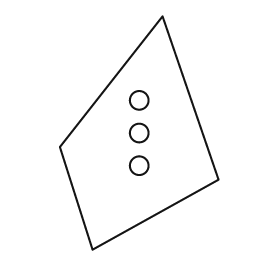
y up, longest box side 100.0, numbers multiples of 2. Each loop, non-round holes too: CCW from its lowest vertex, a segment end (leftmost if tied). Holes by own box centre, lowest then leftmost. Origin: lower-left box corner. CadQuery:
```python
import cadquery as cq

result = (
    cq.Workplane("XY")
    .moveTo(14.0, 0.0)
    .lineTo(68.0, 30.0)
    .lineTo(44.0, 100.0)
    .lineTo(0.0, 44.0)
    .close()
    .moveTo(34.0, 36.0)
    .circle(4.0)
    .moveTo(34.0, 50.0)
    .circle(4.0)
    .moveTo(34.0, 64.0)
    .circle(4.0)
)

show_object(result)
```